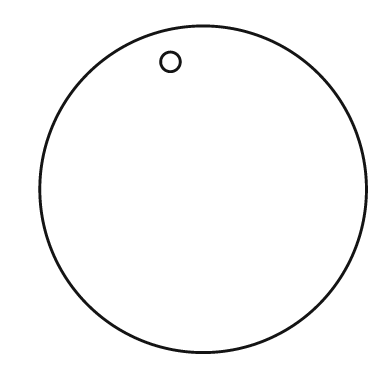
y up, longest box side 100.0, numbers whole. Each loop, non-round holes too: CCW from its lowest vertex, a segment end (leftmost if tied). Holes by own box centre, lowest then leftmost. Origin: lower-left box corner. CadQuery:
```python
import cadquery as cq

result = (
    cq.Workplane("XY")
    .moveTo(50.0, 50.0)
    .circle(50.0)
    .moveTo(40.0, 89.0)
    .circle(3.0)
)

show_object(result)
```